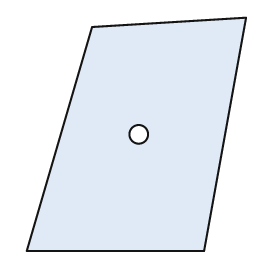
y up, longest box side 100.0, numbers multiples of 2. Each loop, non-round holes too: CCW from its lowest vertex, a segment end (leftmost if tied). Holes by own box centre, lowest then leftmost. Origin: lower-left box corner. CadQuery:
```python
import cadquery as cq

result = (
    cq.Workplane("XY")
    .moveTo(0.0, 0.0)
    .lineTo(76.0, 0.0)
    .lineTo(94.0, 100.0)
    .lineTo(28.0, 96.0)
    .close()
    .moveTo(48.0, 50.0)
    .circle(4.0)
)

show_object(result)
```